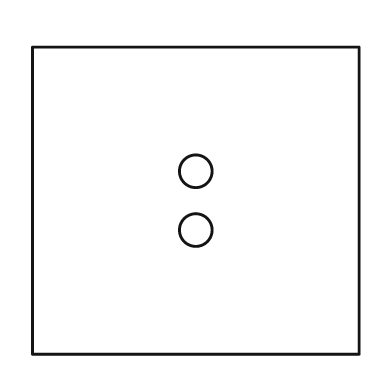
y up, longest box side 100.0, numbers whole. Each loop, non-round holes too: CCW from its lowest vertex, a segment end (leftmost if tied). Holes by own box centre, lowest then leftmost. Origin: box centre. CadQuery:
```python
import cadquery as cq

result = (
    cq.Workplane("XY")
    .moveTo(-50.0, -47.0)
    .lineTo(50.0, -47.0)
    .lineTo(50.0, 47.0)
    .lineTo(-50.0, 47.0)
    .close()
    .moveTo(0.0, -9.0)
    .circle(5.0)
    .moveTo(0.0, 9.0)
    .circle(5.0)
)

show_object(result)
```